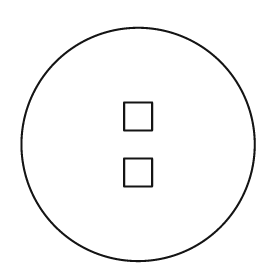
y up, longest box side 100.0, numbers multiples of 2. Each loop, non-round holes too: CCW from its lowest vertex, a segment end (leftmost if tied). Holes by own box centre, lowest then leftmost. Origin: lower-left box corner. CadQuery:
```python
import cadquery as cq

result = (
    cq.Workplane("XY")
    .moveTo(50.0, 50.0)
    .circle(50.0)
    .moveTo(44.0, 32.0)
    .lineTo(56.0, 32.0)
    .lineTo(56.0, 44.0)
    .lineTo(44.0, 44.0)
    .close()
    .moveTo(44.0, 56.0)
    .lineTo(56.0, 56.0)
    .lineTo(56.0, 68.0)
    .lineTo(44.0, 68.0)
    .close()
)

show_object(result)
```